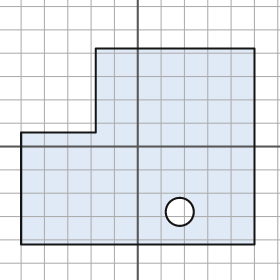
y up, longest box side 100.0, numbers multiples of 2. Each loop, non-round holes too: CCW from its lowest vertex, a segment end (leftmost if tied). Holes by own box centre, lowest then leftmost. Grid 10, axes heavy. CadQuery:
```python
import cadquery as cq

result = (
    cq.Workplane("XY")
    .moveTo(-50.0, -42.0)
    .lineTo(50.0, -42.0)
    .lineTo(50.0, 42.0)
    .lineTo(-18.0, 42.0)
    .lineTo(-18.0, 6.0)
    .lineTo(-50.0, 6.0)
    .close()
    .moveTo(18.0, -28.0)
    .circle(6.0)
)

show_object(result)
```